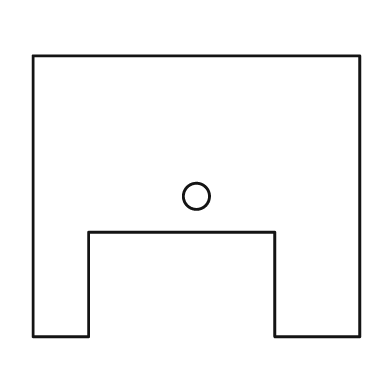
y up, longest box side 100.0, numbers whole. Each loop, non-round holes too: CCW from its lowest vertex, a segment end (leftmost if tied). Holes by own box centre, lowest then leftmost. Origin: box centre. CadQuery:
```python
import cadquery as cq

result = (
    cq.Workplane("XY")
    .moveTo(-50.0, -43.0)
    .lineTo(-33.0, -43.0)
    .lineTo(-33.0, -11.0)
    .lineTo(24.0, -11.0)
    .lineTo(24.0, -43.0)
    .lineTo(50.0, -43.0)
    .lineTo(50.0, 43.0)
    .lineTo(-50.0, 43.0)
    .close()
    .moveTo(0.0, 0.0)
    .circle(4.0)
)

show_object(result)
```